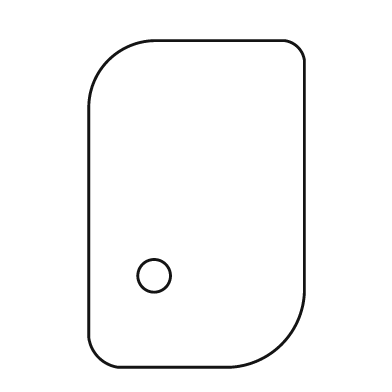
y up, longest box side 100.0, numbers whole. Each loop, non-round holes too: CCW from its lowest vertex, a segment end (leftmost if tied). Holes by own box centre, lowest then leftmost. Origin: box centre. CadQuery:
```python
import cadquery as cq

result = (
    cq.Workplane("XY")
    .moveTo(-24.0, -50.0)
    .lineTo(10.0, -50.0)
    .threePointArc((26.0, -43.0), (33.0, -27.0))
    .lineTo(33.0, 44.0)
    .threePointArc((31.0, 48.0), (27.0, 50.0))
    .lineTo(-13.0, 50.0)
    .threePointArc((-27.0, 44.0), (-33.0, 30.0))
    .lineTo(-33.0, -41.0)
    .threePointArc((-30.0, -47.0), (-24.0, -50.0))
    .close()
    .moveTo(-13.0, -22.0)
    .circle(5.0)
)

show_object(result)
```